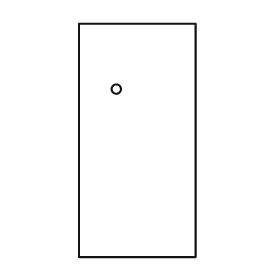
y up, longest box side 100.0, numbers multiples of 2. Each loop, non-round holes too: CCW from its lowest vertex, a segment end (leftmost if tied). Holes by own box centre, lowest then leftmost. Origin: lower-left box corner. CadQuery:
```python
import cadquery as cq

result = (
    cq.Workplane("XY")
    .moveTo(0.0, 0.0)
    .lineTo(50.0, 0.0)
    .lineTo(50.0, 100.0)
    .lineTo(0.0, 100.0)
    .close()
    .moveTo(16.0, 72.0)
    .circle(2.0)
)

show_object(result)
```